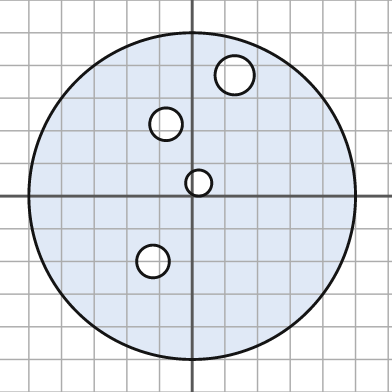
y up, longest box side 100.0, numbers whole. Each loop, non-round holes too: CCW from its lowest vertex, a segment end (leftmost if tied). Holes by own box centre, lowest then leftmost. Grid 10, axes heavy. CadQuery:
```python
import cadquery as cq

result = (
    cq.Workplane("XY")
    .moveTo(0.0, 0.0)
    .circle(50.0)
    .moveTo(-12.0, -20.0)
    .circle(5.0)
    .moveTo(2.0, 4.0)
    .circle(4.0)
    .moveTo(-8.0, 22.0)
    .circle(5.0)
    .moveTo(13.0, 37.0)
    .circle(6.0)
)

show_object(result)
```